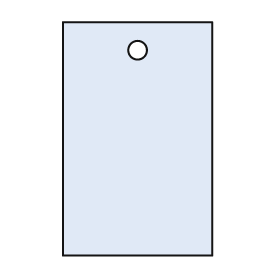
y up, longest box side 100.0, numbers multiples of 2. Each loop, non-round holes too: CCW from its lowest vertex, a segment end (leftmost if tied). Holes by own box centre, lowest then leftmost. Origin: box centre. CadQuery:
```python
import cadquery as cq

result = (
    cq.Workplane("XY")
    .moveTo(-32.0, -50.0)
    .lineTo(32.0, -50.0)
    .lineTo(32.0, 50.0)
    .lineTo(-32.0, 50.0)
    .close()
    .moveTo(0.0, 38.0)
    .circle(4.0)
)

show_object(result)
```